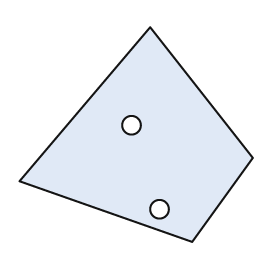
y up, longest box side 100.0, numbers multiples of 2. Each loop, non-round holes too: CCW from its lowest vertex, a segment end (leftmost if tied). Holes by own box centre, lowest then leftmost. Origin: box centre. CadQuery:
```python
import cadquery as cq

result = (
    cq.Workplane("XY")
    .moveTo(24.0, -46.0)
    .lineTo(50.0, -10.0)
    .lineTo(6.0, 46.0)
    .lineTo(-50.0, -20.0)
    .close()
    .moveTo(10.0, -32.0)
    .circle(4.0)
    .moveTo(-2.0, 4.0)
    .circle(4.0)
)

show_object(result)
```